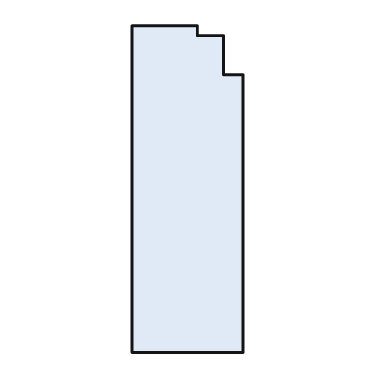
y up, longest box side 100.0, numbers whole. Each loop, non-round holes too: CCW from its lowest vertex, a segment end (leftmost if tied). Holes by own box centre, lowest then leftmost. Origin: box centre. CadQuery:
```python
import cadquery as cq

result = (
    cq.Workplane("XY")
    .moveTo(-17.0, -50.0)
    .lineTo(17.0, -50.0)
    .lineTo(17.0, 35.0)
    .lineTo(11.0, 35.0)
    .lineTo(11.0, 47.0)
    .lineTo(3.0, 47.0)
    .lineTo(3.0, 50.0)
    .lineTo(-17.0, 50.0)
    .close()
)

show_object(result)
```